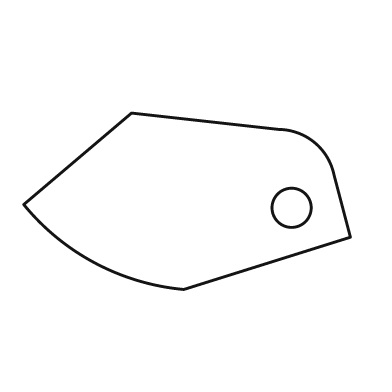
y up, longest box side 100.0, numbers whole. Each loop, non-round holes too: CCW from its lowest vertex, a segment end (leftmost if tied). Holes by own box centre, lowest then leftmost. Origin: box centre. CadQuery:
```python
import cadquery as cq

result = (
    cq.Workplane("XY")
    .moveTo(-1.0, -27.0)
    .lineTo(50.0, -11.0)
    .lineTo(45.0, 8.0)
    .threePointArc((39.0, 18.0), (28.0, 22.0))
    .lineTo(-17.0, 27.0)
    .lineTo(-50.0, -1.0)
    .threePointArc((-28.0, -19.0), (-1.0, -27.0))
    .close()
    .moveTo(32.0, -2.0)
    .circle(6.0)
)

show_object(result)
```